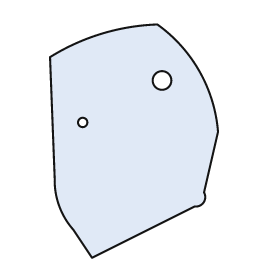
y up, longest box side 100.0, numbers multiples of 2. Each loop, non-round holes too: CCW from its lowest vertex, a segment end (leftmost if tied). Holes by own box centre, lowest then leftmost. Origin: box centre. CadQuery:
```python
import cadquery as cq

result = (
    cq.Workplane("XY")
    .moveTo(-18.0, -50.0)
    .lineTo(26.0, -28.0)
    .threePointArc((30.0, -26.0), (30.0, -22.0))
    .lineTo(36.0, 4.0)
    .threePointArc((28.0, 30.0), (10.0, 50.0))
    .threePointArc((-14.0, 46.0), (-36.0, 36.0))
    .lineTo(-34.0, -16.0)
    .threePointArc((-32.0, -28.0), (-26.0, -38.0))
    .close()
    .moveTo(-22.0, 8.0)
    .circle(2.0)
    .moveTo(12.0, 26.0)
    .circle(4.0)
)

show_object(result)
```